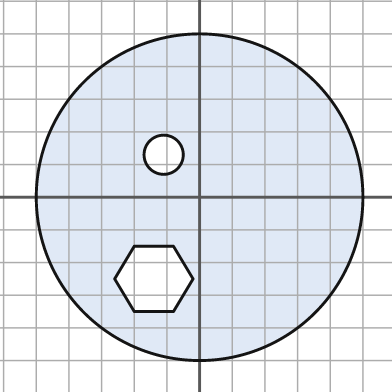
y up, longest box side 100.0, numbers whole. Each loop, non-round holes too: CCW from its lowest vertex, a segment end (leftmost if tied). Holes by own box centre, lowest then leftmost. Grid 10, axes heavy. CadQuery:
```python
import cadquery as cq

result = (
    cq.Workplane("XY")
    .moveTo(0.0, 0.0)
    .circle(50.0)
    .moveTo(-20.0, -35.0)
    .lineTo(-8.0, -35.0)
    .lineTo(-2.0, -25.0)
    .lineTo(-8.0, -15.0)
    .lineTo(-20.0, -15.0)
    .lineTo(-26.0, -25.0)
    .close()
    .moveTo(-11.0, 13.0)
    .circle(6.0)
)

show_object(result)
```